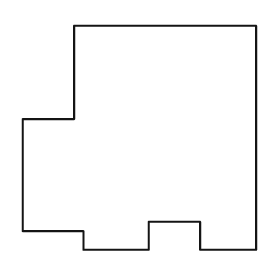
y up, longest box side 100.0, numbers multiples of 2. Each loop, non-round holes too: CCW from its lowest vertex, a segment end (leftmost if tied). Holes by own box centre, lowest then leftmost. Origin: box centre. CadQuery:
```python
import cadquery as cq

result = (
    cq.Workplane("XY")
    .moveTo(-24.0, -48.0)
    .lineTo(4.0, -48.0)
    .lineTo(4.0, -36.0)
    .lineTo(26.0, -36.0)
    .lineTo(26.0, -48.0)
    .lineTo(50.0, -48.0)
    .lineTo(50.0, 48.0)
    .lineTo(-28.0, 48.0)
    .lineTo(-28.0, 8.0)
    .lineTo(-50.0, 8.0)
    .lineTo(-50.0, -40.0)
    .lineTo(-24.0, -40.0)
    .close()
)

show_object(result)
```